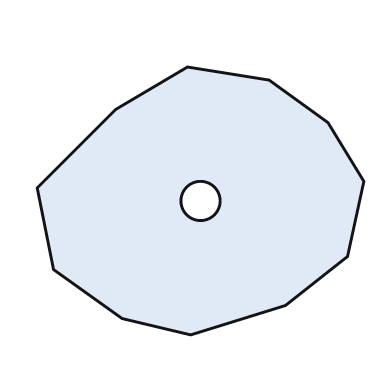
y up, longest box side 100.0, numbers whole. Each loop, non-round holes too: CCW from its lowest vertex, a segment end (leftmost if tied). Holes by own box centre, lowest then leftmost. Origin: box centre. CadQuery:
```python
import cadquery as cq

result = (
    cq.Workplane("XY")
    .moveTo(-3.0, -41.0)
    .lineTo(26.0, -32.0)
    .lineTo(45.0, -17.0)
    .lineTo(50.0, 6.0)
    .lineTo(39.0, 24.0)
    .lineTo(21.0, 37.0)
    .lineTo(-4.0, 41.0)
    .lineTo(-26.0, 28.0)
    .lineTo(-50.0, 4.0)
    .lineTo(-45.0, -21.0)
    .lineTo(-24.0, -36.0)
    .close()
    .moveTo(0.0, 0.0)
    .circle(6.0)
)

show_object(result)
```